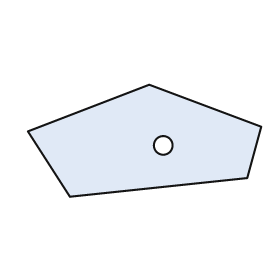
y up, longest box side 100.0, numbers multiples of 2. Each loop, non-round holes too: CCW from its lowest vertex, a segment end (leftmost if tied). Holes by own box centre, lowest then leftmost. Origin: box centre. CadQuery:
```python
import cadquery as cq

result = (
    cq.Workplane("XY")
    .moveTo(-32.0, -24.0)
    .lineTo(44.0, -16.0)
    .lineTo(50.0, 6.0)
    .lineTo(2.0, 24.0)
    .lineTo(-50.0, 4.0)
    .close()
    .moveTo(8.0, -2.0)
    .circle(4.0)
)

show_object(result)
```